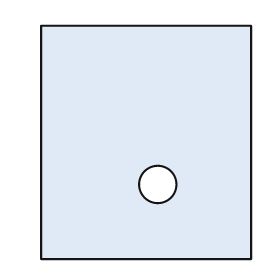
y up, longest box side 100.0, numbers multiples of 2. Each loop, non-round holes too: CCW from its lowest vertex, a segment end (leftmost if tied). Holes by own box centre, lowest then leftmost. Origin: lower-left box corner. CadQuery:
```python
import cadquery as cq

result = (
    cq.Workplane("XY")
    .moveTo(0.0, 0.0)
    .lineTo(90.0, 0.0)
    .lineTo(90.0, 100.0)
    .lineTo(0.0, 100.0)
    .close()
    .moveTo(50.0, 32.0)
    .circle(8.0)
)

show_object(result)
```